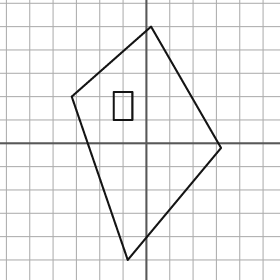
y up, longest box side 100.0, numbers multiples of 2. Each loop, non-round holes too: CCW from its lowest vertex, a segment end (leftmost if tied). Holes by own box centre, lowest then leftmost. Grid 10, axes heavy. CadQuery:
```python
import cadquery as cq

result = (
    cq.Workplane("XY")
    .moveTo(-8.0, -50.0)
    .lineTo(32.0, -2.0)
    .lineTo(2.0, 50.0)
    .lineTo(-32.0, 20.0)
    .close()
    .moveTo(-14.0, 10.0)
    .lineTo(-6.0, 10.0)
    .lineTo(-6.0, 22.0)
    .lineTo(-14.0, 22.0)
    .close()
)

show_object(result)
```